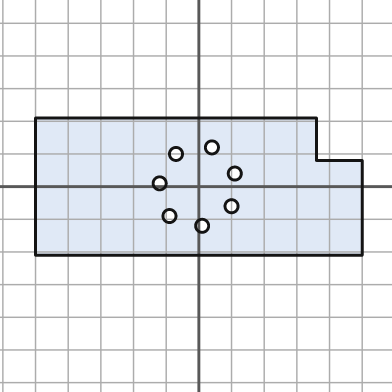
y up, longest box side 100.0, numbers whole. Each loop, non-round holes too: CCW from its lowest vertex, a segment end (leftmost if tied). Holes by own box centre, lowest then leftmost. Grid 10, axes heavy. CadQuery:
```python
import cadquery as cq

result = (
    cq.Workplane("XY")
    .moveTo(-50.0, -21.0)
    .lineTo(50.0, -21.0)
    .lineTo(50.0, 8.0)
    .lineTo(36.0, 8.0)
    .lineTo(36.0, 21.0)
    .lineTo(-50.0, 21.0)
    .close()
    .moveTo(1.0, -12.0)
    .circle(2.0)
    .moveTo(-9.0, -9.0)
    .circle(2.0)
    .moveTo(10.0, -6.0)
    .circle(2.0)
    .moveTo(-12.0, 1.0)
    .circle(2.0)
    .moveTo(11.0, 4.0)
    .circle(2.0)
    .moveTo(-7.0, 10.0)
    .circle(2.0)
    .moveTo(4.0, 12.0)
    .circle(2.0)
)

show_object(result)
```